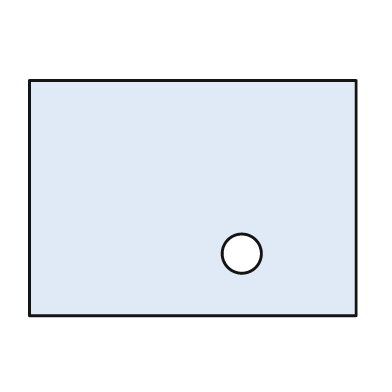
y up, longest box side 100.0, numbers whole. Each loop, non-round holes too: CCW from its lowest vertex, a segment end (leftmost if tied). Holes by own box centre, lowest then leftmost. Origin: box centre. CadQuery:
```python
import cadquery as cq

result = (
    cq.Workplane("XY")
    .moveTo(-50.0, -36.0)
    .lineTo(50.0, -36.0)
    .lineTo(50.0, 36.0)
    .lineTo(-50.0, 36.0)
    .close()
    .moveTo(15.0, -17.0)
    .circle(6.0)
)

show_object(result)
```